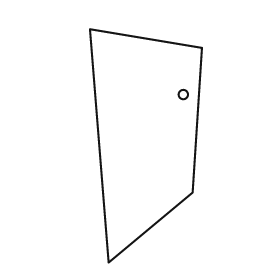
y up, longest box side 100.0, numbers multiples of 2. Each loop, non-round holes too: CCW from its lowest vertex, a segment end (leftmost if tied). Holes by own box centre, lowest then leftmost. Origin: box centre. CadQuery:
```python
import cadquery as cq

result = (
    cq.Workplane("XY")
    .moveTo(-16.0, -50.0)
    .lineTo(20.0, -20.0)
    .lineTo(24.0, 42.0)
    .lineTo(-24.0, 50.0)
    .close()
    .moveTo(16.0, 22.0)
    .circle(2.0)
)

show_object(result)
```